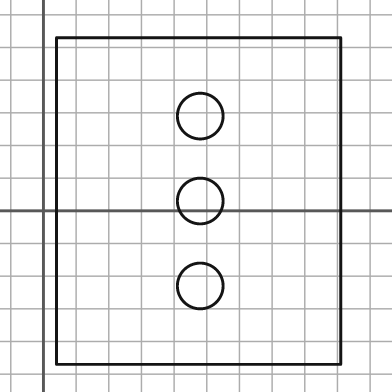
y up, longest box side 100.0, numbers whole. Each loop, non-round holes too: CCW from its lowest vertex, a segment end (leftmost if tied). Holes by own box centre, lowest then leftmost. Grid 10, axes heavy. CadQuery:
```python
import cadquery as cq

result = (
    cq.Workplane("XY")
    .moveTo(4.0, -47.0)
    .lineTo(91.0, -47.0)
    .lineTo(91.0, 53.0)
    .lineTo(4.0, 53.0)
    .close()
    .moveTo(48.0, -23.0)
    .circle(7.0)
    .moveTo(48.0, 3.0)
    .circle(7.0)
    .moveTo(48.0, 29.0)
    .circle(7.0)
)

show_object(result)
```